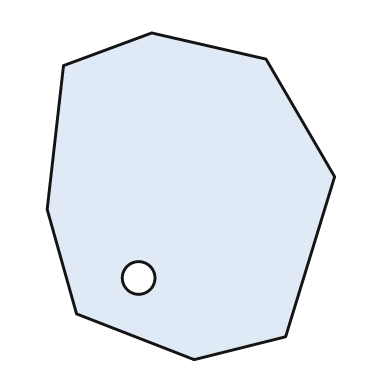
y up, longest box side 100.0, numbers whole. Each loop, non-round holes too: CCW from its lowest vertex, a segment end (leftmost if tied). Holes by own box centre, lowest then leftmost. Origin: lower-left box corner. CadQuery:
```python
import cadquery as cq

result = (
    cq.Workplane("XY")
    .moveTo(45.0, 0.0)
    .lineTo(73.0, 7.0)
    .lineTo(88.0, 56.0)
    .lineTo(67.0, 92.0)
    .lineTo(32.0, 100.0)
    .lineTo(5.0, 90.0)
    .lineTo(0.0, 46.0)
    .lineTo(9.0, 14.0)
    .close()
    .moveTo(28.0, 25.0)
    .circle(5.0)
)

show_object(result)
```